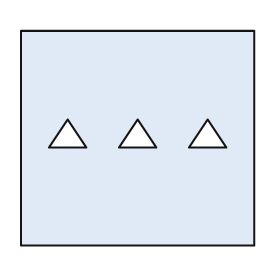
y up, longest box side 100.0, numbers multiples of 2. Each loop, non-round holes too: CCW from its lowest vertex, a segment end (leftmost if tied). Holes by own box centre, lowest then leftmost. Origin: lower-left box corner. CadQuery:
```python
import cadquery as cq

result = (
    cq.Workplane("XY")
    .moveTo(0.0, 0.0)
    .lineTo(100.0, 0.0)
    .lineTo(100.0, 92.0)
    .lineTo(0.0, 92.0)
    .close()
    .moveTo(12.0, 42.0)
    .lineTo(28.0, 42.0)
    .lineTo(20.0, 54.0)
    .close()
    .moveTo(42.0, 42.0)
    .lineTo(58.0, 42.0)
    .lineTo(50.0, 54.0)
    .close()
    .moveTo(72.0, 42.0)
    .lineTo(88.0, 42.0)
    .lineTo(80.0, 54.0)
    .close()
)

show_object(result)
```